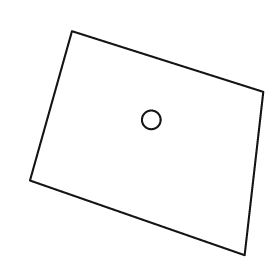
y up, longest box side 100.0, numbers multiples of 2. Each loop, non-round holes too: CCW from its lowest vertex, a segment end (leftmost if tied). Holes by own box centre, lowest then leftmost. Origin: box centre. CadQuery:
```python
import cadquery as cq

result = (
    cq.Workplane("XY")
    .moveTo(42.0, -48.0)
    .lineTo(50.0, 22.0)
    .lineTo(-32.0, 48.0)
    .lineTo(-50.0, -16.0)
    .close()
    .moveTo(2.0, 10.0)
    .circle(4.0)
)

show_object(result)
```